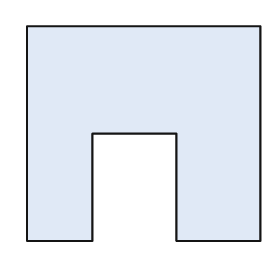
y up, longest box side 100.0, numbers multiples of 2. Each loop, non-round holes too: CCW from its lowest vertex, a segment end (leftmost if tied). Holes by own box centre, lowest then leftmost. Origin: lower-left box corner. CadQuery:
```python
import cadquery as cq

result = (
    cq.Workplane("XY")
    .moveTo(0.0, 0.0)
    .lineTo(28.0, 0.0)
    .lineTo(28.0, 46.0)
    .lineTo(64.0, 46.0)
    .lineTo(64.0, 0.0)
    .lineTo(100.0, 0.0)
    .lineTo(100.0, 92.0)
    .lineTo(0.0, 92.0)
    .close()
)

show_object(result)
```